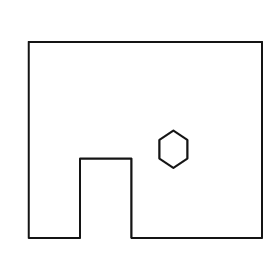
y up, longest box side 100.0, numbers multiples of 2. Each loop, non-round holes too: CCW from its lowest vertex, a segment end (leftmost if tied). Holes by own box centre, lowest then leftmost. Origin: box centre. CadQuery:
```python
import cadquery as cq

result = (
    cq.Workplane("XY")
    .moveTo(-50.0, -42.0)
    .lineTo(-28.0, -42.0)
    .lineTo(-28.0, -8.0)
    .lineTo(-6.0, -8.0)
    .lineTo(-6.0, -42.0)
    .lineTo(50.0, -42.0)
    .lineTo(50.0, 42.0)
    .lineTo(-50.0, 42.0)
    .close()
    .moveTo(12.0, -12.0)
    .lineTo(18.0, -8.0)
    .lineTo(18.0, 0.0)
    .lineTo(12.0, 4.0)
    .lineTo(6.0, 0.0)
    .lineTo(6.0, -8.0)
    .close()
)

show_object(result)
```